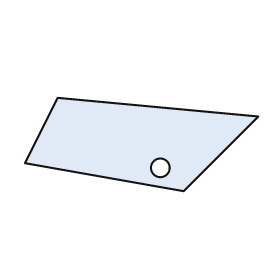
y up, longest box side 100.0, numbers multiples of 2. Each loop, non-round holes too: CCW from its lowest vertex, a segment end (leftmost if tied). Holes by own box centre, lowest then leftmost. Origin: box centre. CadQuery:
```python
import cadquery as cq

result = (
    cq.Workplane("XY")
    .moveTo(18.0, -20.0)
    .lineTo(50.0, 12.0)
    .lineTo(-36.0, 20.0)
    .lineTo(-50.0, -8.0)
    .close()
    .moveTo(8.0, -10.0)
    .circle(4.0)
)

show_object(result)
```